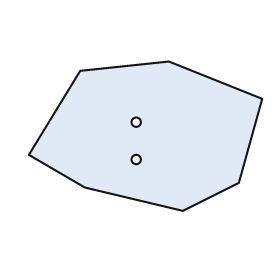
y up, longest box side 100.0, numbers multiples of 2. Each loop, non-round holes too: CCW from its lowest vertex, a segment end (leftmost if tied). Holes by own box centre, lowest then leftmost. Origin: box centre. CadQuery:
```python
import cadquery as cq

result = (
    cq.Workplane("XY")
    .moveTo(16.0, -32.0)
    .lineTo(40.0, -20.0)
    .lineTo(50.0, 16.0)
    .lineTo(10.0, 32.0)
    .lineTo(-28.0, 28.0)
    .lineTo(-50.0, -8.0)
    .lineTo(-26.0, -22.0)
    .close()
    .moveTo(-4.0, -10.0)
    .circle(2.0)
    .moveTo(-4.0, 6.0)
    .circle(2.0)
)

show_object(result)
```